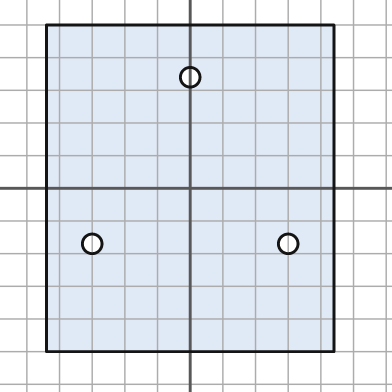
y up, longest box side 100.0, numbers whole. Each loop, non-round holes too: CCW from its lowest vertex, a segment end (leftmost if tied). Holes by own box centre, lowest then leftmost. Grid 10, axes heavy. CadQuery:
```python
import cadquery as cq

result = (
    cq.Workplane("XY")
    .moveTo(-44.0, -50.0)
    .lineTo(44.0, -50.0)
    .lineTo(44.0, 50.0)
    .lineTo(-44.0, 50.0)
    .close()
    .moveTo(-30.0, -17.0)
    .circle(3.0)
    .moveTo(30.0, -17.0)
    .circle(3.0)
    .moveTo(0.0, 34.0)
    .circle(3.0)
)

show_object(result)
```